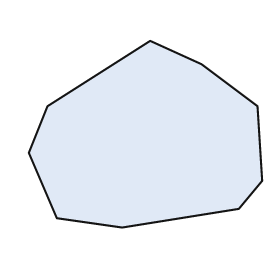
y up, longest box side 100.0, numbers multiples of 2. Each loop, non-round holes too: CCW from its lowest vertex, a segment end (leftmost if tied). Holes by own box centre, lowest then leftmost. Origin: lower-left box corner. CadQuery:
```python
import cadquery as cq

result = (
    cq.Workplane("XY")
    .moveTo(40.0, 0.0)
    .lineTo(90.0, 8.0)
    .lineTo(100.0, 20.0)
    .lineTo(98.0, 52.0)
    .lineTo(74.0, 70.0)
    .lineTo(52.0, 80.0)
    .lineTo(8.0, 52.0)
    .lineTo(0.0, 32.0)
    .lineTo(12.0, 4.0)
    .close()
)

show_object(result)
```